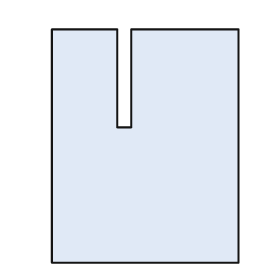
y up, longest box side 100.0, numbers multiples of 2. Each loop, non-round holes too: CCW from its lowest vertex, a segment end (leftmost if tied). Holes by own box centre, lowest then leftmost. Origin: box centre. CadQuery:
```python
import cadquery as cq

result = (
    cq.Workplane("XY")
    .moveTo(-40.0, -50.0)
    .lineTo(40.0, -50.0)
    .lineTo(40.0, 50.0)
    .lineTo(-6.0, 50.0)
    .lineTo(-6.0, 8.0)
    .lineTo(-12.0, 8.0)
    .lineTo(-12.0, 50.0)
    .lineTo(-40.0, 50.0)
    .close()
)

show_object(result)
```